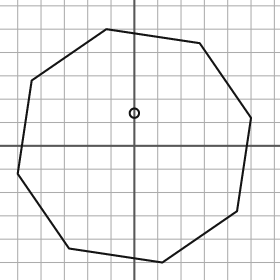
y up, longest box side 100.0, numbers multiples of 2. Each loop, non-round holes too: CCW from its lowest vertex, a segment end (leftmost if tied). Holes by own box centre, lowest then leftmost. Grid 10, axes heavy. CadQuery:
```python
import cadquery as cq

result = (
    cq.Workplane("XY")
    .moveTo(12.0, -50.0)
    .lineTo(44.0, -28.0)
    .lineTo(50.0, 12.0)
    .lineTo(28.0, 44.0)
    .lineTo(-12.0, 50.0)
    .lineTo(-44.0, 28.0)
    .lineTo(-50.0, -12.0)
    .lineTo(-28.0, -44.0)
    .close()
    .moveTo(0.0, 14.0)
    .circle(2.0)
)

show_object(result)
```